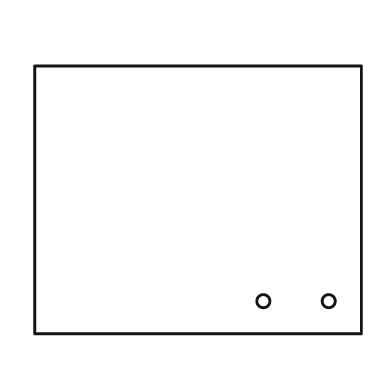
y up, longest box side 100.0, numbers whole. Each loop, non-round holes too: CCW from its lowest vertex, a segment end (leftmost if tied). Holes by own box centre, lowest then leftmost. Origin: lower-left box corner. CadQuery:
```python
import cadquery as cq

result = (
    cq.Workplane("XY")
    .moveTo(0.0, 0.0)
    .lineTo(100.0, 0.0)
    .lineTo(100.0, 82.0)
    .lineTo(0.0, 82.0)
    .close()
    .moveTo(70.0, 10.0)
    .circle(2.0)
    .moveTo(90.0, 10.0)
    .circle(2.0)
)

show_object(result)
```